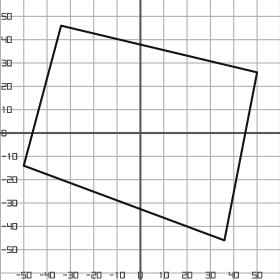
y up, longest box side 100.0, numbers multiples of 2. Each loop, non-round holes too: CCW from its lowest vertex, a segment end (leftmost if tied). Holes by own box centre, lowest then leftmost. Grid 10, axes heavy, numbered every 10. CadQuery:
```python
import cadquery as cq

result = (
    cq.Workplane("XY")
    .moveTo(36.0, -46.0)
    .lineTo(50.0, 26.0)
    .lineTo(-34.0, 46.0)
    .lineTo(-50.0, -14.0)
    .close()
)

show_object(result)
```